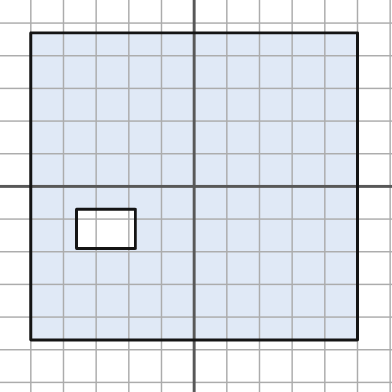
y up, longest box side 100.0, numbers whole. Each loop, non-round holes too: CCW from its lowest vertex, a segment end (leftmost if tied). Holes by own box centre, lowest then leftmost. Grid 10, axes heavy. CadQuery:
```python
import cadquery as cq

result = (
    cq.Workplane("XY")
    .moveTo(-50.0, -47.0)
    .lineTo(50.0, -47.0)
    .lineTo(50.0, 47.0)
    .lineTo(-50.0, 47.0)
    .close()
    .moveTo(-36.0, -19.0)
    .lineTo(-18.0, -19.0)
    .lineTo(-18.0, -7.0)
    .lineTo(-36.0, -7.0)
    .close()
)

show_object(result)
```